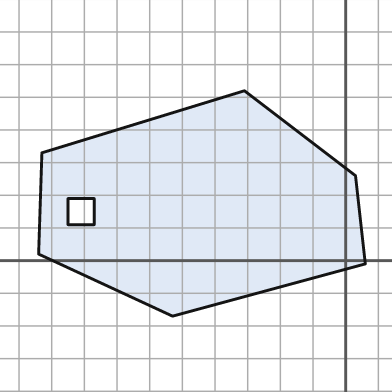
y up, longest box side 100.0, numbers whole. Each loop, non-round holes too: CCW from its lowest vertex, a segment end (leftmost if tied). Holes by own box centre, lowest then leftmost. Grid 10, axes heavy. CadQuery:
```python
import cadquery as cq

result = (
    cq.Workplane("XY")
    .moveTo(-53.0, -17.0)
    .lineTo(6.0, -1.0)
    .lineTo(3.0, 26.0)
    .lineTo(-31.0, 52.0)
    .lineTo(-93.0, 33.0)
    .lineTo(-94.0, 2.0)
    .close()
    .moveTo(-85.0, 11.0)
    .lineTo(-77.0, 11.0)
    .lineTo(-77.0, 19.0)
    .lineTo(-85.0, 19.0)
    .close()
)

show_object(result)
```